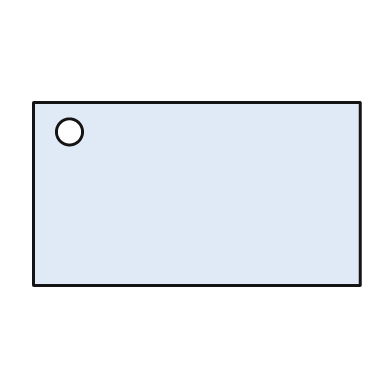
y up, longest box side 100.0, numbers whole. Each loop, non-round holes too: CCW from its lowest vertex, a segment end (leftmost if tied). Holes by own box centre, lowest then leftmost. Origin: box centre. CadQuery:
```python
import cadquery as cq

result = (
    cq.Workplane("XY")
    .moveTo(-50.0, -28.0)
    .lineTo(50.0, -28.0)
    .lineTo(50.0, 28.0)
    .lineTo(-50.0, 28.0)
    .close()
    .moveTo(-39.0, 19.0)
    .circle(4.0)
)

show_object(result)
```